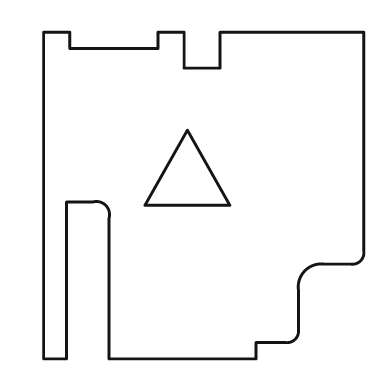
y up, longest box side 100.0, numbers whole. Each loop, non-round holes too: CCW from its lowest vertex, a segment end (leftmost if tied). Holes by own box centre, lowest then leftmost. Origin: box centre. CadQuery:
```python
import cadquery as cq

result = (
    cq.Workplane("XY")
    .moveTo(-49.0, -50.0)
    .lineTo(-42.0, -50.0)
    .lineTo(-42.0, -2.0)
    .lineTo(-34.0, -2.0)
    .threePointArc((-30.0, -3.0), (-29.0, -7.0))
    .lineTo(-29.0, -50.0)
    .lineTo(16.0, -50.0)
    .lineTo(16.0, -45.0)
    .lineTo(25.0, -45.0)
    .threePointArc((28.0, -44.0), (29.0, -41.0))
    .lineTo(29.0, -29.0)
    .threePointArc((31.0, -23.0), (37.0, -21.0))
    .lineTo(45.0, -21.0)
    .threePointArc((48.0, -20.0), (49.0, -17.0))
    .lineTo(49.0, 50.0)
    .lineTo(5.0, 50.0)
    .lineTo(5.0, 39.0)
    .lineTo(-6.0, 39.0)
    .lineTo(-6.0, 50.0)
    .lineTo(-14.0, 50.0)
    .lineTo(-14.0, 45.0)
    .lineTo(-41.0, 45.0)
    .lineTo(-41.0, 50.0)
    .lineTo(-49.0, 50.0)
    .close()
    .moveTo(-18.0, -3.0)
    .lineTo(8.0, -3.0)
    .lineTo(-5.0, 20.0)
    .close()
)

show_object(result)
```